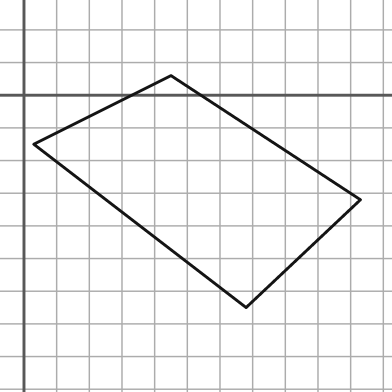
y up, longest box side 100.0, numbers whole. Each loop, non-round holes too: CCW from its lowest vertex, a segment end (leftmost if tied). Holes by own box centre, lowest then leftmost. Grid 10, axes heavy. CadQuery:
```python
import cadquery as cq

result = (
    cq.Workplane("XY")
    .moveTo(68.0, -65.0)
    .lineTo(103.0, -32.0)
    .lineTo(45.0, 6.0)
    .lineTo(3.0, -15.0)
    .close()
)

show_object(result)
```